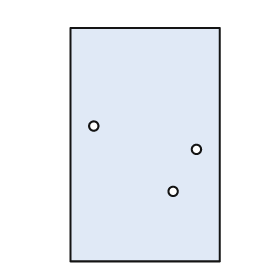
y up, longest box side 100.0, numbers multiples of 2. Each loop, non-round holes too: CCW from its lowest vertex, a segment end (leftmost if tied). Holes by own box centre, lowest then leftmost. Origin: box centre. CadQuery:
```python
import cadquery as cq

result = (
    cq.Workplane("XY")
    .moveTo(-32.0, -50.0)
    .lineTo(32.0, -50.0)
    .lineTo(32.0, 50.0)
    .lineTo(-32.0, 50.0)
    .close()
    .moveTo(12.0, -20.0)
    .circle(2.0)
    .moveTo(22.0, -2.0)
    .circle(2.0)
    .moveTo(-22.0, 8.0)
    .circle(2.0)
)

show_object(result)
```